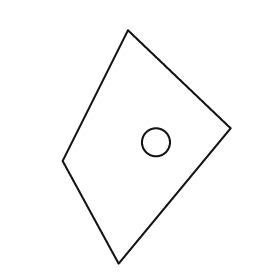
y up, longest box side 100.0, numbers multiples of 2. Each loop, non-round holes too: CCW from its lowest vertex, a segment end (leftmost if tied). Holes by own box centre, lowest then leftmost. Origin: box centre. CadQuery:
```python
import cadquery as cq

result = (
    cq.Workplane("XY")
    .moveTo(-12.0, -50.0)
    .lineTo(36.0, 8.0)
    .lineTo(-8.0, 50.0)
    .lineTo(-36.0, -6.0)
    .close()
    .moveTo(4.0, 2.0)
    .circle(6.0)
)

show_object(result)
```